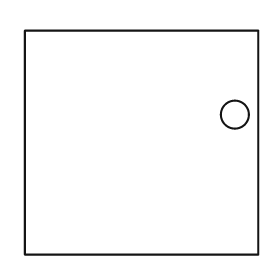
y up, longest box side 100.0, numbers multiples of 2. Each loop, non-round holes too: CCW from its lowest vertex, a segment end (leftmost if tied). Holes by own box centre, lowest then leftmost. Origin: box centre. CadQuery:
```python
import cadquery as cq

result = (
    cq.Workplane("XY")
    .moveTo(-50.0, -48.0)
    .lineTo(50.0, -48.0)
    .lineTo(50.0, 48.0)
    .lineTo(-50.0, 48.0)
    .close()
    .moveTo(40.0, 12.0)
    .circle(6.0)
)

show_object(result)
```